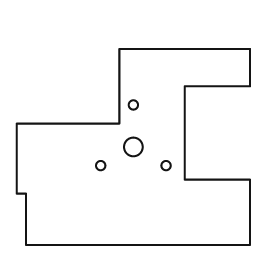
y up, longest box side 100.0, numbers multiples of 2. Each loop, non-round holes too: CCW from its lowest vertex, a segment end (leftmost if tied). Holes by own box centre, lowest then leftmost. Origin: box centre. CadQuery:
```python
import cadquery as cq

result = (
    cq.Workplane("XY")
    .moveTo(-46.0, -42.0)
    .lineTo(50.0, -42.0)
    .lineTo(50.0, -14.0)
    .lineTo(22.0, -14.0)
    .lineTo(22.0, 26.0)
    .lineTo(50.0, 26.0)
    .lineTo(50.0, 42.0)
    .lineTo(-6.0, 42.0)
    .lineTo(-6.0, 10.0)
    .lineTo(-50.0, 10.0)
    .lineTo(-50.0, -20.0)
    .lineTo(-46.0, -20.0)
    .close()
    .moveTo(-14.0, -8.0)
    .circle(2.0)
    .moveTo(14.0, -8.0)
    .circle(2.0)
    .moveTo(0.0, 0.0)
    .circle(4.0)
    .moveTo(0.0, 18.0)
    .circle(2.0)
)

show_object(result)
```